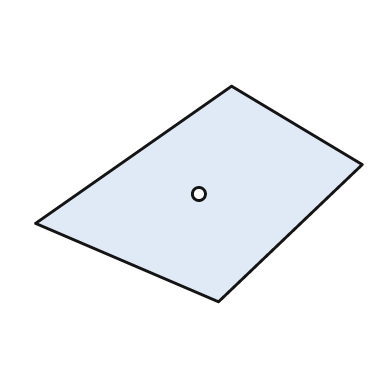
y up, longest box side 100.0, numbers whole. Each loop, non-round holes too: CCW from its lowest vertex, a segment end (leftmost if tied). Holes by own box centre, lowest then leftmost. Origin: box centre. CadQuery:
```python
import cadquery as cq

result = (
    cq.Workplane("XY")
    .moveTo(6.0, -33.0)
    .lineTo(50.0, 9.0)
    .lineTo(10.0, 33.0)
    .lineTo(-50.0, -9.0)
    .close()
    .moveTo(0.0, 0.0)
    .circle(2.0)
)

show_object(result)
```